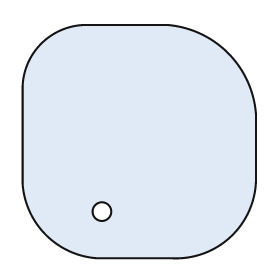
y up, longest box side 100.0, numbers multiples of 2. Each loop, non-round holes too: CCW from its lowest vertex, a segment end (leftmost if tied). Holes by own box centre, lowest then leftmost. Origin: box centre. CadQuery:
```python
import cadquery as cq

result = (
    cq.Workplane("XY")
    .moveTo(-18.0, -50.0)
    .lineTo(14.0, -50.0)
    .threePointArc((40.0, -40.0), (50.0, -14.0))
    .lineTo(50.0, 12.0)
    .threePointArc((38.0, 38.0), (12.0, 50.0))
    .lineTo(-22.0, 50.0)
    .threePointArc((-42.0, 42.0), (-50.0, 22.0))
    .lineTo(-50.0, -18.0)
    .threePointArc((-40.0, -40.0), (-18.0, -50.0))
    .close()
    .moveTo(-16.0, -30.0)
    .circle(4.0)
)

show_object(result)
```